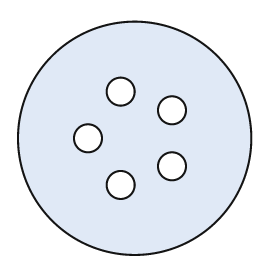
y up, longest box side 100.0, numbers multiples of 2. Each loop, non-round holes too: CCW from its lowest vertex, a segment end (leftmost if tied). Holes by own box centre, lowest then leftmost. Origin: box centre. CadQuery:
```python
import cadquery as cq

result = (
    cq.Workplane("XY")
    .moveTo(0.0, 0.0)
    .circle(50.0)
    .moveTo(-6.0, -20.0)
    .circle(6.0)
    .moveTo(16.0, -12.0)
    .circle(6.0)
    .moveTo(-20.0, 0.0)
    .circle(6.0)
    .moveTo(16.0, 12.0)
    .circle(6.0)
    .moveTo(-6.0, 20.0)
    .circle(6.0)
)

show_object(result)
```